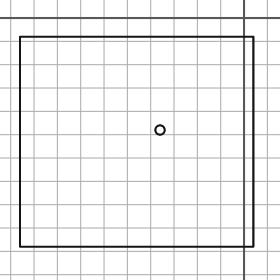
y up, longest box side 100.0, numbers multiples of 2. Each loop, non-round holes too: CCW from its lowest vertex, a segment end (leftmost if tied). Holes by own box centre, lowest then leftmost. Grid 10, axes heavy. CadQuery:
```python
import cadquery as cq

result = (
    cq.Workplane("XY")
    .moveTo(-96.0, -98.0)
    .lineTo(4.0, -98.0)
    .lineTo(4.0, -8.0)
    .lineTo(-96.0, -8.0)
    .close()
    .moveTo(-36.0, -48.0)
    .circle(2.0)
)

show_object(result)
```